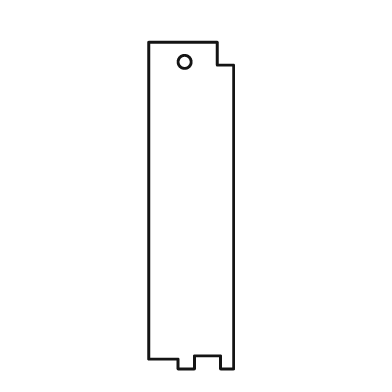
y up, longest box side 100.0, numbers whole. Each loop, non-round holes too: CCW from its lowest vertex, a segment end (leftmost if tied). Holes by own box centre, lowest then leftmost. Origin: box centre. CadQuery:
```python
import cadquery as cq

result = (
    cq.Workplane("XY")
    .moveTo(-4.0, -50.0)
    .lineTo(1.0, -50.0)
    .lineTo(1.0, -46.0)
    .lineTo(9.0, -46.0)
    .lineTo(9.0, -50.0)
    .lineTo(13.0, -50.0)
    .lineTo(13.0, 43.0)
    .lineTo(8.0, 43.0)
    .lineTo(8.0, 50.0)
    .lineTo(-13.0, 50.0)
    .lineTo(-13.0, -47.0)
    .lineTo(-4.0, -47.0)
    .close()
    .moveTo(-2.0, 44.0)
    .circle(2.0)
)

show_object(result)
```